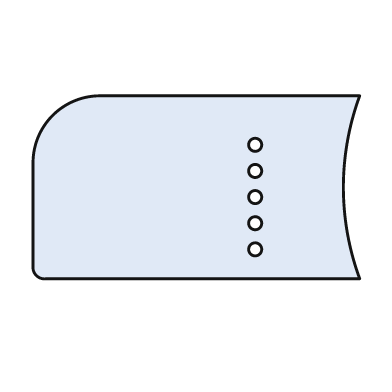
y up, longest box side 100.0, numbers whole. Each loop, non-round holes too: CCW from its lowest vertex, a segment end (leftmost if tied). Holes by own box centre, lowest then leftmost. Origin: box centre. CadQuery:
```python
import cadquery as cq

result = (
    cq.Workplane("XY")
    .moveTo(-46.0, -28.0)
    .lineTo(50.0, -28.0)
    .threePointArc((45.0, 0.0), (50.0, 28.0))
    .lineTo(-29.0, 28.0)
    .threePointArc((-44.0, 22.0), (-50.0, 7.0))
    .lineTo(-50.0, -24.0)
    .threePointArc((-49.0, -27.0), (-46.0, -28.0))
    .close()
    .moveTo(18.0, -19.0)
    .circle(2.0)
    .moveTo(18.0, -11.0)
    .circle(2.0)
    .moveTo(18.0, -3.0)
    .circle(2.0)
    .moveTo(18.0, 5.0)
    .circle(2.0)
    .moveTo(18.0, 13.0)
    .circle(2.0)
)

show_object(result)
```